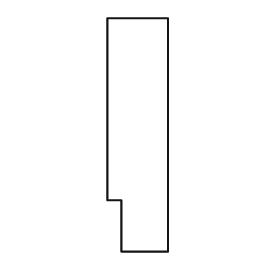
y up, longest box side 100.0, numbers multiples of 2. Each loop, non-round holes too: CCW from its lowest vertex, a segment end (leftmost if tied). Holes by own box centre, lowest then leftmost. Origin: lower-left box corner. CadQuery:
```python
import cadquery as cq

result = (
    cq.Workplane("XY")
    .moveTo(6.0, 0.0)
    .lineTo(26.0, 0.0)
    .lineTo(26.0, 100.0)
    .lineTo(0.0, 100.0)
    .lineTo(0.0, 22.0)
    .lineTo(6.0, 22.0)
    .close()
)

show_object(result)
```